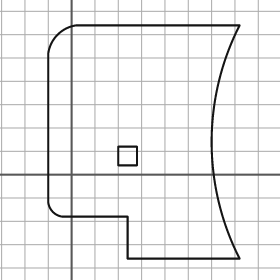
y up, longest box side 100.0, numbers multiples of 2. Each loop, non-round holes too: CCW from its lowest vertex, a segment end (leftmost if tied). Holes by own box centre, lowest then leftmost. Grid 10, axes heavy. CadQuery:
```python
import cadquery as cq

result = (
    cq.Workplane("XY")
    .moveTo(24.0, -36.0)
    .lineTo(72.0, -36.0)
    .threePointArc((60.0, 14.0), (72.0, 64.0))
    .lineTo(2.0, 64.0)
    .threePointArc((-6.0, 60.0), (-10.0, 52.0))
    .lineTo(-10.0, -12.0)
    .threePointArc((-8.0, -16.0), (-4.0, -18.0))
    .lineTo(24.0, -18.0)
    .close()
    .moveTo(20.0, 4.0)
    .lineTo(28.0, 4.0)
    .lineTo(28.0, 12.0)
    .lineTo(20.0, 12.0)
    .close()
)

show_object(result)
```